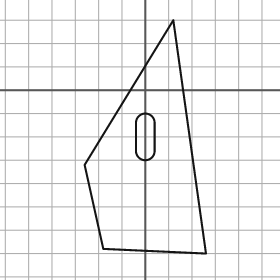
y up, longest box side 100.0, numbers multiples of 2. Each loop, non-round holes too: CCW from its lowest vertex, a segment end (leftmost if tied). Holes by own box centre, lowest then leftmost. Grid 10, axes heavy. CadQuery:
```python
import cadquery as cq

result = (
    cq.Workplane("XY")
    .moveTo(26.0, -70.0)
    .lineTo(12.0, 30.0)
    .lineTo(-26.0, -32.0)
    .lineTo(-18.0, -68.0)
    .close()
    .moveTo(-4.0, -26.0)
    .threePointArc((0.0, -30.0), (4.0, -26.0))
    .lineTo(4.0, -14.0)
    .threePointArc((0.0, -10.0), (-4.0, -14.0))
    .close()
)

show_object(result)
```